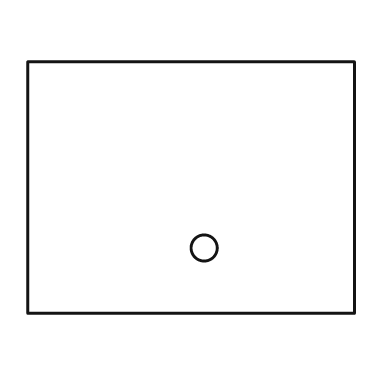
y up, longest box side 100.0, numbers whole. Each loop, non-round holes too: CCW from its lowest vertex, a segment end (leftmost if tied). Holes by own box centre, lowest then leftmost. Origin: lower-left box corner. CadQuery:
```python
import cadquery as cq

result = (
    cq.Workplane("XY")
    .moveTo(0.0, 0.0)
    .lineTo(100.0, 0.0)
    .lineTo(100.0, 77.0)
    .lineTo(0.0, 77.0)
    .close()
    .moveTo(54.0, 20.0)
    .circle(4.0)
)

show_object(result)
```